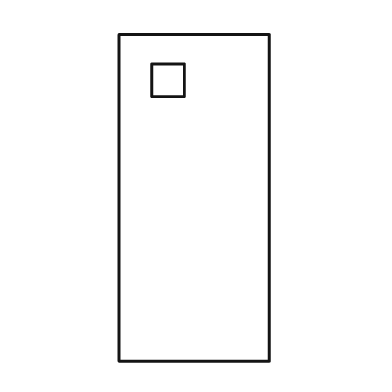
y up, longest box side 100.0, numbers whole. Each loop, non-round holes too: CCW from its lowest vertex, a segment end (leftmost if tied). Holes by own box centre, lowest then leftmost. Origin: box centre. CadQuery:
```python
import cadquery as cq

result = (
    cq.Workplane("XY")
    .moveTo(-23.0, -50.0)
    .lineTo(23.0, -50.0)
    .lineTo(23.0, 50.0)
    .lineTo(-23.0, 50.0)
    .close()
    .moveTo(-13.0, 31.0)
    .lineTo(-3.0, 31.0)
    .lineTo(-3.0, 41.0)
    .lineTo(-13.0, 41.0)
    .close()
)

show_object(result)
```